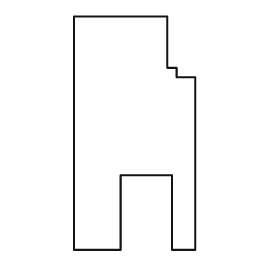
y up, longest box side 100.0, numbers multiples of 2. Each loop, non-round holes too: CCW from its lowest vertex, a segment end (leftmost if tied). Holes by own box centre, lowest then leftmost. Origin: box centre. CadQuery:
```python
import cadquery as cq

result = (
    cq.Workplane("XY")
    .moveTo(-26.0, -50.0)
    .lineTo(-6.0, -50.0)
    .lineTo(-6.0, -18.0)
    .lineTo(16.0, -18.0)
    .lineTo(16.0, -50.0)
    .lineTo(26.0, -50.0)
    .lineTo(26.0, 24.0)
    .lineTo(18.0, 24.0)
    .lineTo(18.0, 28.0)
    .lineTo(14.0, 28.0)
    .lineTo(14.0, 50.0)
    .lineTo(-26.0, 50.0)
    .close()
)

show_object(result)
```